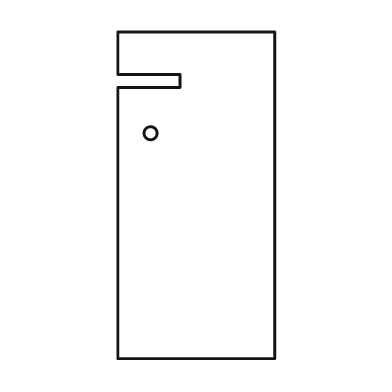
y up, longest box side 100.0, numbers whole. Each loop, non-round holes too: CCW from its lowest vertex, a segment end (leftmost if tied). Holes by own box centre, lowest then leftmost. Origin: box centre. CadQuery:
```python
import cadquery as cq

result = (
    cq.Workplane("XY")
    .moveTo(-24.0, -50.0)
    .lineTo(24.0, -50.0)
    .lineTo(24.0, 50.0)
    .lineTo(-24.0, 50.0)
    .lineTo(-24.0, 37.0)
    .lineTo(-5.0, 37.0)
    .lineTo(-5.0, 33.0)
    .lineTo(-24.0, 33.0)
    .close()
    .moveTo(-14.0, 19.0)
    .circle(2.0)
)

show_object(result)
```